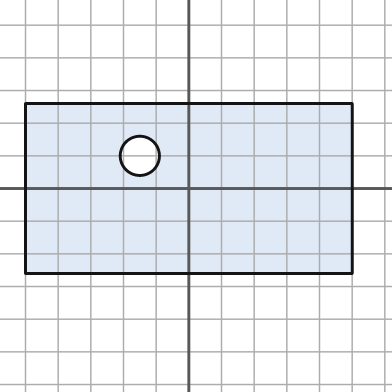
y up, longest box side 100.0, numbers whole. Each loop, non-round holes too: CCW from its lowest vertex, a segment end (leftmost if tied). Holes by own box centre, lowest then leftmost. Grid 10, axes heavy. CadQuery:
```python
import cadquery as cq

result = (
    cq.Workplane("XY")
    .moveTo(-50.0, -26.0)
    .lineTo(50.0, -26.0)
    .lineTo(50.0, 26.0)
    .lineTo(-50.0, 26.0)
    .close()
    .moveTo(-15.0, 10.0)
    .circle(6.0)
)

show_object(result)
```